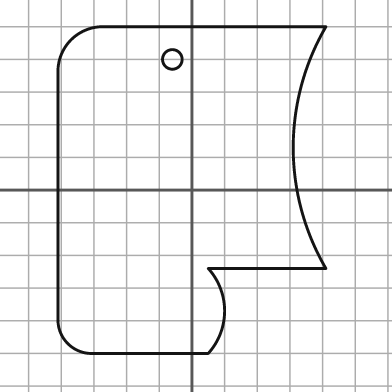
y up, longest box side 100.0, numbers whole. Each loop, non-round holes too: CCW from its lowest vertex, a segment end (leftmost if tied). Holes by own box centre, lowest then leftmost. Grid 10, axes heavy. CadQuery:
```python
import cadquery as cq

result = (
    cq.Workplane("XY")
    .moveTo(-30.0, -50.0)
    .lineTo(5.0, -50.0)
    .threePointArc((10.0, -37.0), (5.0, -24.0))
    .lineTo(41.0, -24.0)
    .threePointArc((31.0, 13.0), (41.0, 50.0))
    .lineTo(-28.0, 50.0)
    .threePointArc((-37.0, 46.0), (-41.0, 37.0))
    .lineTo(-41.0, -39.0)
    .threePointArc((-38.0, -47.0), (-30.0, -50.0))
    .close()
    .moveTo(-6.0, 40.0)
    .circle(3.0)
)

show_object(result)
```